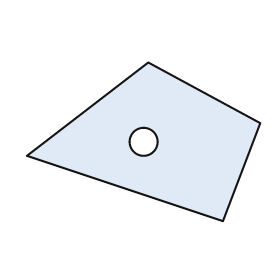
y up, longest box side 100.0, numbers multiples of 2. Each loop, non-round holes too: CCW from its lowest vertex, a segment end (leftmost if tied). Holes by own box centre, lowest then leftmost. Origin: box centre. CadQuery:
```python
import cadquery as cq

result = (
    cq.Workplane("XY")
    .moveTo(34.0, -34.0)
    .lineTo(50.0, 8.0)
    .lineTo(2.0, 34.0)
    .lineTo(-50.0, -6.0)
    .close()
    .moveTo(0.0, 0.0)
    .circle(6.0)
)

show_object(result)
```